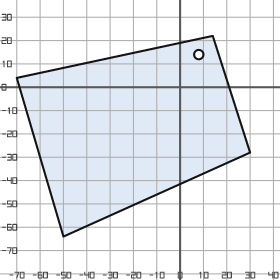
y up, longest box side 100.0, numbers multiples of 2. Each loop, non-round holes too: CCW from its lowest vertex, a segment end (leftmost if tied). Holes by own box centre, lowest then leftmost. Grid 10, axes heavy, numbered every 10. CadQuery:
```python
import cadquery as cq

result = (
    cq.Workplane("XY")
    .moveTo(-50.0, -64.0)
    .lineTo(30.0, -28.0)
    .lineTo(14.0, 22.0)
    .lineTo(-70.0, 4.0)
    .close()
    .moveTo(8.0, 14.0)
    .circle(2.0)
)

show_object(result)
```